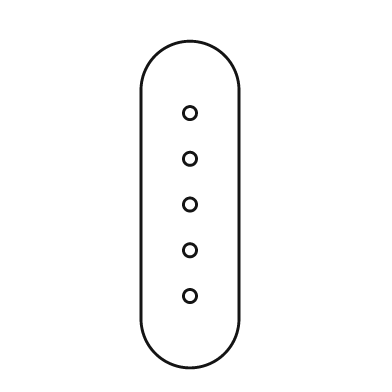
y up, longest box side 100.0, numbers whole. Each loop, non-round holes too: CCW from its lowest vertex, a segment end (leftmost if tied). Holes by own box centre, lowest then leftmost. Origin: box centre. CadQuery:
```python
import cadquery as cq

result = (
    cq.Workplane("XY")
    .moveTo(-15.0, -35.0)
    .threePointArc((0.0, -50.0), (15.0, -35.0))
    .lineTo(15.0, 35.0)
    .threePointArc((0.0, 50.0), (-15.0, 35.0))
    .close()
    .moveTo(0.0, -28.0)
    .circle(2.0)
    .moveTo(0.0, -14.0)
    .circle(2.0)
    .moveTo(0.0, 0.0)
    .circle(2.0)
    .moveTo(0.0, 14.0)
    .circle(2.0)
    .moveTo(0.0, 28.0)
    .circle(2.0)
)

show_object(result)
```